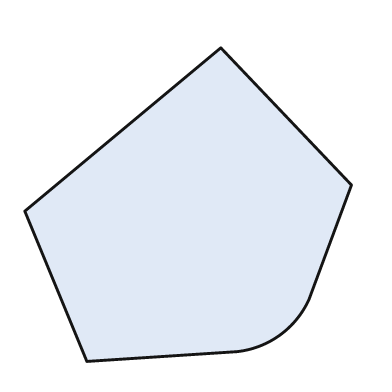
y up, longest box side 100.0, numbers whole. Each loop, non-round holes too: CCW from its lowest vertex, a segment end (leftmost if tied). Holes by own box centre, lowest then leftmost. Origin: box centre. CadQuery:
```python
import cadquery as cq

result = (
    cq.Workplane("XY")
    .moveTo(-31.0, -48.0)
    .lineTo(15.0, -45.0)
    .threePointArc((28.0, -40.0), (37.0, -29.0))
    .lineTo(50.0, 6.0)
    .lineTo(10.0, 48.0)
    .lineTo(-50.0, -2.0)
    .close()
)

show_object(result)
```